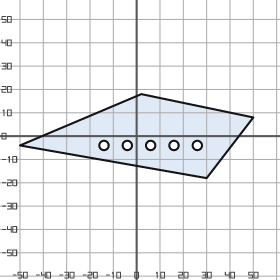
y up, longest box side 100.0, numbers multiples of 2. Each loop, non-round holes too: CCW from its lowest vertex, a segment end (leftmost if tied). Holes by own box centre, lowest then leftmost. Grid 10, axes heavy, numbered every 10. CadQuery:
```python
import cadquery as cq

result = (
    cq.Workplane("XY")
    .moveTo(30.0, -18.0)
    .lineTo(50.0, 8.0)
    .lineTo(2.0, 18.0)
    .lineTo(-50.0, -4.0)
    .close()
    .moveTo(-14.0, -4.0)
    .circle(2.0)
    .moveTo(-4.0, -4.0)
    .circle(2.0)
    .moveTo(6.0, -4.0)
    .circle(2.0)
    .moveTo(16.0, -4.0)
    .circle(2.0)
    .moveTo(26.0, -4.0)
    .circle(2.0)
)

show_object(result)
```